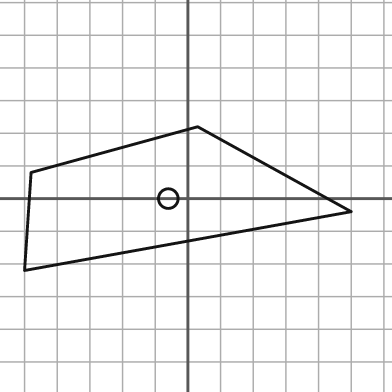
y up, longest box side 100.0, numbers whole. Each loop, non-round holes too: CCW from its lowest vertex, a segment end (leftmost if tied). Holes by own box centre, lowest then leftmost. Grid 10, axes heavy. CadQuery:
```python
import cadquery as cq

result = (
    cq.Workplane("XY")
    .moveTo(-50.0, -22.0)
    .lineTo(50.0, -4.0)
    .lineTo(3.0, 22.0)
    .lineTo(-48.0, 8.0)
    .close()
    .moveTo(-6.0, 0.0)
    .circle(3.0)
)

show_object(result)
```